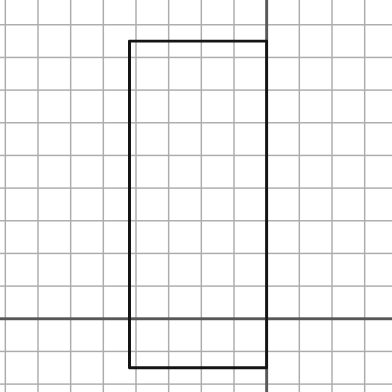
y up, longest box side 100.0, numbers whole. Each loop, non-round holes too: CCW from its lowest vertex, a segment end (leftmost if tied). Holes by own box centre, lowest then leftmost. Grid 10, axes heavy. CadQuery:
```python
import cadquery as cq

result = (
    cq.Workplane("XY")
    .moveTo(-42.0, -15.0)
    .lineTo(0.0, -15.0)
    .lineTo(0.0, 85.0)
    .lineTo(-42.0, 85.0)
    .close()
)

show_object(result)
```